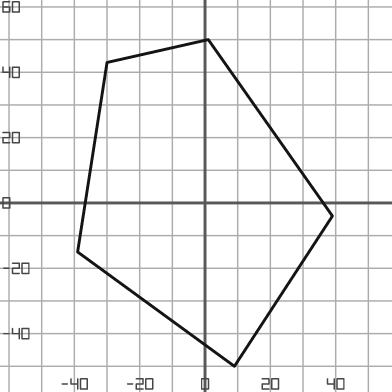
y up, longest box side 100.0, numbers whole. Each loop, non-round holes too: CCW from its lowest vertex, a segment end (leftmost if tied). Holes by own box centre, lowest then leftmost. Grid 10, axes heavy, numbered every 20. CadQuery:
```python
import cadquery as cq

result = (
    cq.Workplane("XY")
    .moveTo(9.0, -50.0)
    .lineTo(39.0, -4.0)
    .lineTo(1.0, 50.0)
    .lineTo(-30.0, 43.0)
    .lineTo(-39.0, -15.0)
    .close()
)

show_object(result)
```